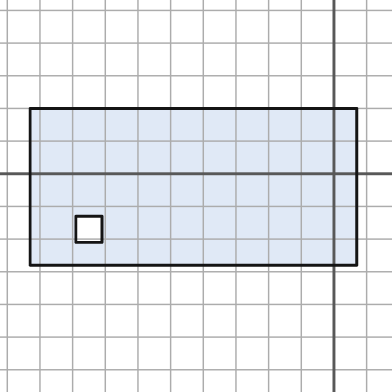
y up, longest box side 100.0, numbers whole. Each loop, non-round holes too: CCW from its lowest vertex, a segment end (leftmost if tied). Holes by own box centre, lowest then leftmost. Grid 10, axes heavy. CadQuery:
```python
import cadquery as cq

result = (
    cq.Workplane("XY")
    .moveTo(-93.0, -28.0)
    .lineTo(7.0, -28.0)
    .lineTo(7.0, 20.0)
    .lineTo(-93.0, 20.0)
    .close()
    .moveTo(-79.0, -21.0)
    .lineTo(-71.0, -21.0)
    .lineTo(-71.0, -13.0)
    .lineTo(-79.0, -13.0)
    .close()
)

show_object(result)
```